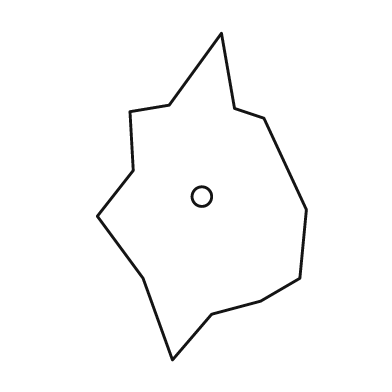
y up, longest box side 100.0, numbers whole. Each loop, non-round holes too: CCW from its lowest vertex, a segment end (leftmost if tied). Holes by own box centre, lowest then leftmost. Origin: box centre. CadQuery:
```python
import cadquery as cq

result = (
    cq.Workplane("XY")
    .moveTo(-9.0, -50.0)
    .lineTo(3.0, -36.0)
    .lineTo(18.0, -32.0)
    .lineTo(30.0, -25.0)
    .lineTo(32.0, -4.0)
    .lineTo(19.0, 24.0)
    .lineTo(10.0, 27.0)
    .lineTo(6.0, 50.0)
    .lineTo(-10.0, 28.0)
    .lineTo(-22.0, 26.0)
    .lineTo(-21.0, 8.0)
    .lineTo(-32.0, -6.0)
    .lineTo(-18.0, -25.0)
    .close()
    .moveTo(0.0, 0.0)
    .circle(3.0)
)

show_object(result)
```